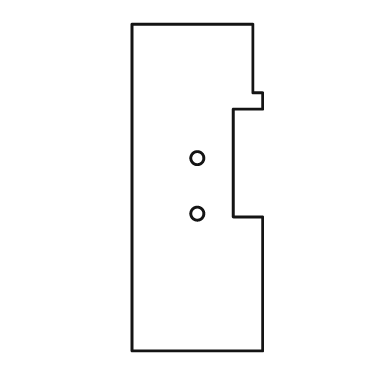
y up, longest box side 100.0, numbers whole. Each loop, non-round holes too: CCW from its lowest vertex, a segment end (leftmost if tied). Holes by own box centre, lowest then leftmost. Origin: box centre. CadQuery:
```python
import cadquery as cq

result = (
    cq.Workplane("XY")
    .moveTo(-20.0, -50.0)
    .lineTo(20.0, -50.0)
    .lineTo(20.0, -9.0)
    .lineTo(11.0, -9.0)
    .lineTo(11.0, 24.0)
    .lineTo(20.0, 24.0)
    .lineTo(20.0, 29.0)
    .lineTo(17.0, 29.0)
    .lineTo(17.0, 50.0)
    .lineTo(-20.0, 50.0)
    .close()
    .moveTo(0.0, -8.0)
    .circle(2.0)
    .moveTo(0.0, 9.0)
    .circle(2.0)
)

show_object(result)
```